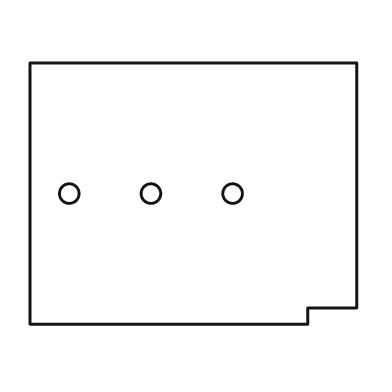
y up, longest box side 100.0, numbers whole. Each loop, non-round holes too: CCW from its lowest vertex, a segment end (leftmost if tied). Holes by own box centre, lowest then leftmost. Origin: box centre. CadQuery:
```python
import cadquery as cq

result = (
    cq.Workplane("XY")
    .moveTo(-50.0, -40.0)
    .lineTo(35.0, -40.0)
    .lineTo(35.0, -35.0)
    .lineTo(50.0, -35.0)
    .lineTo(50.0, 40.0)
    .lineTo(-50.0, 40.0)
    .close()
    .moveTo(-38.0, 0.0)
    .circle(3.0)
    .moveTo(-13.0, 0.0)
    .circle(3.0)
    .moveTo(12.0, 0.0)
    .circle(3.0)
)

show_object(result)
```